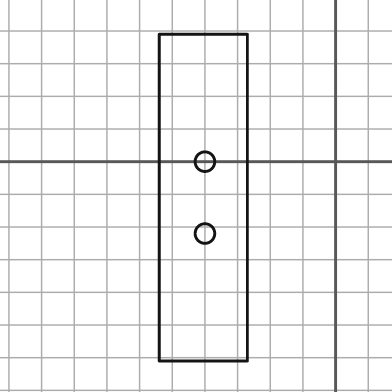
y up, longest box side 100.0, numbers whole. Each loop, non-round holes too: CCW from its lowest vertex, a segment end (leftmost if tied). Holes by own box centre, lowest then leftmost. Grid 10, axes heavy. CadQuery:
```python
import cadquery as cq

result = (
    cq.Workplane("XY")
    .moveTo(-54.0, -61.0)
    .lineTo(-27.0, -61.0)
    .lineTo(-27.0, 39.0)
    .lineTo(-54.0, 39.0)
    .close()
    .moveTo(-40.0, -22.0)
    .circle(3.0)
    .moveTo(-40.0, 0.0)
    .circle(3.0)
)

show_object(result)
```